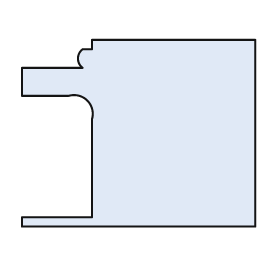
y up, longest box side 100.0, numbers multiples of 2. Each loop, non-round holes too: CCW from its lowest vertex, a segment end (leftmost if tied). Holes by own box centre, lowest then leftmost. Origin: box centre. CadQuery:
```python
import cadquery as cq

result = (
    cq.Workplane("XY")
    .moveTo(-50.0, -40.0)
    .lineTo(50.0, -40.0)
    .lineTo(50.0, 40.0)
    .lineTo(-20.0, 40.0)
    .lineTo(-20.0, 36.0)
    .lineTo(-24.0, 36.0)
    .threePointArc((-26.0, 32.0), (-24.0, 28.0))
    .lineTo(-50.0, 28.0)
    .lineTo(-50.0, 16.0)
    .lineTo(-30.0, 16.0)
    .threePointArc((-22.0, 14.0), (-20.0, 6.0))
    .lineTo(-20.0, -36.0)
    .lineTo(-50.0, -36.0)
    .close()
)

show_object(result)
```